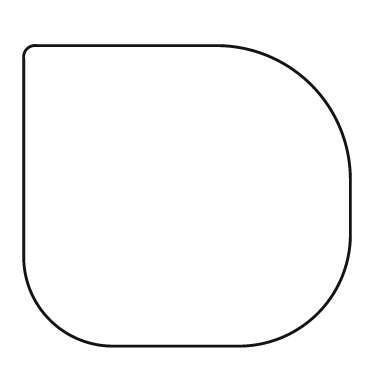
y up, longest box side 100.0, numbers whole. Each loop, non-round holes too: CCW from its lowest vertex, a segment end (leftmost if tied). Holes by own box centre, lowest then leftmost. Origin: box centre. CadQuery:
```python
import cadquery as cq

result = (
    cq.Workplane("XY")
    .moveTo(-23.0, -46.0)
    .lineTo(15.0, -46.0)
    .threePointArc((40.0, -36.0), (50.0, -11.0))
    .lineTo(50.0, 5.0)
    .threePointArc((38.0, 34.0), (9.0, 46.0))
    .lineTo(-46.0, 46.0)
    .threePointArc((-49.0, 45.0), (-50.0, 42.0))
    .lineTo(-50.0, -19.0)
    .threePointArc((-42.0, -38.0), (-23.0, -46.0))
    .close()
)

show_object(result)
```